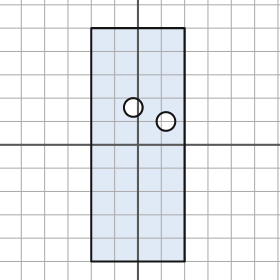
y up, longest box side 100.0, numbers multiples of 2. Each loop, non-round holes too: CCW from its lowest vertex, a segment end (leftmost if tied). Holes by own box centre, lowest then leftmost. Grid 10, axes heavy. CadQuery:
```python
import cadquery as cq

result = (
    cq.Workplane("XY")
    .moveTo(-20.0, -50.0)
    .lineTo(20.0, -50.0)
    .lineTo(20.0, 50.0)
    .lineTo(-20.0, 50.0)
    .close()
    .moveTo(12.0, 10.0)
    .circle(4.0)
    .moveTo(-2.0, 16.0)
    .circle(4.0)
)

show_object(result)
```